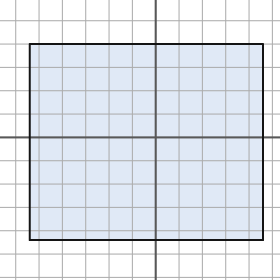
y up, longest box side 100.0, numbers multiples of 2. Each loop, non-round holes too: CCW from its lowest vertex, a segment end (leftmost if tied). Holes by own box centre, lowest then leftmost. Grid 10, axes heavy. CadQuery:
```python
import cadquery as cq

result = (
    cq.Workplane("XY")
    .moveTo(-54.0, -44.0)
    .lineTo(46.0, -44.0)
    .lineTo(46.0, 40.0)
    .lineTo(-54.0, 40.0)
    .close()
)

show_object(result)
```